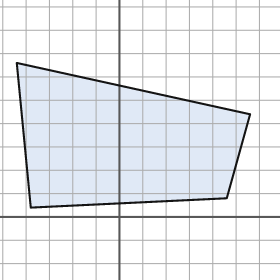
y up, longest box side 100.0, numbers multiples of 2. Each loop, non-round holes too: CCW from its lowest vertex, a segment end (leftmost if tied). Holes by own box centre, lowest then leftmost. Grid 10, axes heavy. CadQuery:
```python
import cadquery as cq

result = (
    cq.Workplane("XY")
    .moveTo(-38.0, 4.0)
    .lineTo(46.0, 8.0)
    .lineTo(56.0, 44.0)
    .lineTo(-44.0, 66.0)
    .close()
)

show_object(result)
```